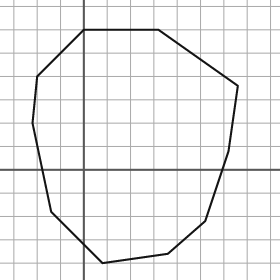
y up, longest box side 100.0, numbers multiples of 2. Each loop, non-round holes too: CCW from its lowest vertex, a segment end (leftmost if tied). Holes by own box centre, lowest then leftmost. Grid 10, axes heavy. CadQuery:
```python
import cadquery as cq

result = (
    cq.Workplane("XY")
    .moveTo(8.0, -40.0)
    .lineTo(36.0, -36.0)
    .lineTo(52.0, -22.0)
    .lineTo(62.0, 8.0)
    .lineTo(66.0, 36.0)
    .lineTo(32.0, 60.0)
    .lineTo(0.0, 60.0)
    .lineTo(-20.0, 40.0)
    .lineTo(-22.0, 20.0)
    .lineTo(-14.0, -18.0)
    .close()
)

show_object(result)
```